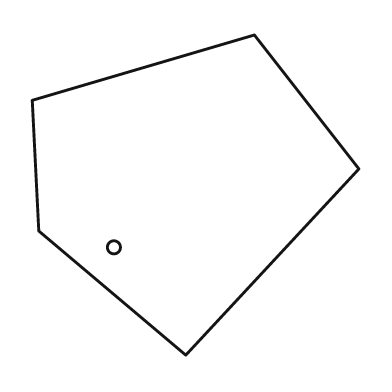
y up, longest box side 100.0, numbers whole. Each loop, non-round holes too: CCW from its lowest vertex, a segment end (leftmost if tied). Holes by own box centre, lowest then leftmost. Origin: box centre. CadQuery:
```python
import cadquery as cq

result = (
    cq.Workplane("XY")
    .moveTo(-3.0, -49.0)
    .lineTo(50.0, 8.0)
    .lineTo(18.0, 49.0)
    .lineTo(-50.0, 29.0)
    .lineTo(-48.0, -11.0)
    .close()
    .moveTo(-25.0, -16.0)
    .circle(2.0)
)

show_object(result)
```